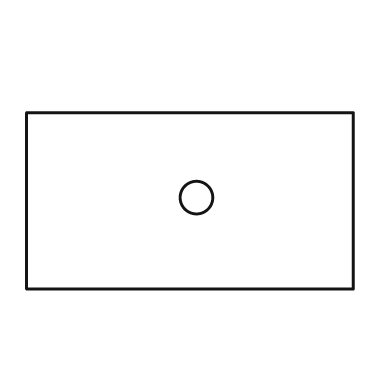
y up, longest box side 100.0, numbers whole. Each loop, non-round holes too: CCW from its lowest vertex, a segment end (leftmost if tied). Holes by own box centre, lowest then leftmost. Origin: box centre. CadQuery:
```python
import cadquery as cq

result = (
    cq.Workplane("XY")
    .moveTo(-50.0, -27.0)
    .lineTo(50.0, -27.0)
    .lineTo(50.0, 27.0)
    .lineTo(-50.0, 27.0)
    .close()
    .moveTo(2.0, 1.0)
    .circle(5.0)
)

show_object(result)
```